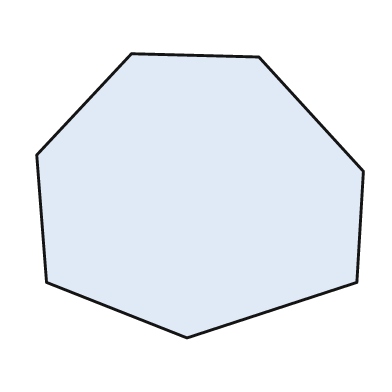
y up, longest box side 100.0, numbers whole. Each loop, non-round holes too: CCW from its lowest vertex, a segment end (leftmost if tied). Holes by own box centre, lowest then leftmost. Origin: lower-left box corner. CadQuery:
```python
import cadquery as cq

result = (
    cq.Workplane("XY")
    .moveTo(46.0, 0.0)
    .lineTo(98.0, 17.0)
    .lineTo(100.0, 51.0)
    .lineTo(68.0, 86.0)
    .lineTo(29.0, 87.0)
    .lineTo(0.0, 56.0)
    .lineTo(3.0, 17.0)
    .close()
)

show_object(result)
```